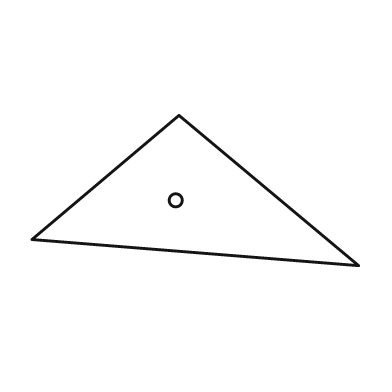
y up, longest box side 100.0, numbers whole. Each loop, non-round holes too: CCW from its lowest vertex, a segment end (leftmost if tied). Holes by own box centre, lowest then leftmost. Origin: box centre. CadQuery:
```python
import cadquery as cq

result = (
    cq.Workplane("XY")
    .moveTo(50.0, -23.0)
    .lineTo(-5.0, 23.0)
    .lineTo(-50.0, -15.0)
    .close()
    .moveTo(-6.0, -3.0)
    .circle(2.0)
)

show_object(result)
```